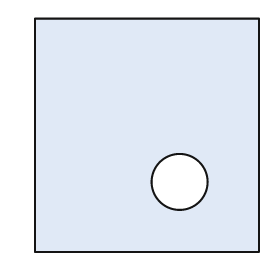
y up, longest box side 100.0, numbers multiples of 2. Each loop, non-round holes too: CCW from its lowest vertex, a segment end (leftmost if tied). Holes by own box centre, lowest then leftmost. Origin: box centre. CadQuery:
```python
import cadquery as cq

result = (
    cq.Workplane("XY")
    .moveTo(-48.0, -50.0)
    .lineTo(48.0, -50.0)
    .lineTo(48.0, 50.0)
    .lineTo(-48.0, 50.0)
    .close()
    .moveTo(14.0, -20.0)
    .circle(12.0)
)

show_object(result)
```